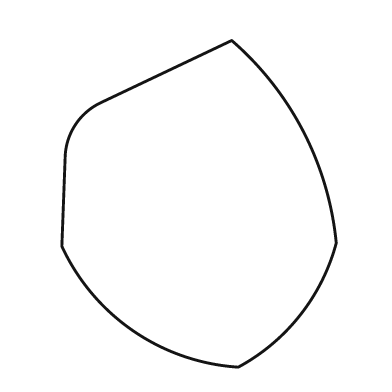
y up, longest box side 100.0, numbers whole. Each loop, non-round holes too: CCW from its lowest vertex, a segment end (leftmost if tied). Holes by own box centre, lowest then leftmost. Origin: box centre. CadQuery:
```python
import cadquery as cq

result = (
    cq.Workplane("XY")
    .moveTo(12.0, -50.0)
    .threePointArc((31.0, -34.0), (42.0, -12.0))
    .threePointArc((32.0, 22.0), (10.0, 50.0))
    .lineTo(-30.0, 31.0)
    .threePointArc((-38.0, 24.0), (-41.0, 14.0))
    .lineTo(-42.0, -13.0)
    .threePointArc((-20.0, -39.0), (12.0, -50.0))
    .close()
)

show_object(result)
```